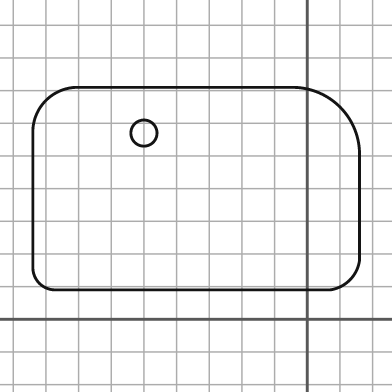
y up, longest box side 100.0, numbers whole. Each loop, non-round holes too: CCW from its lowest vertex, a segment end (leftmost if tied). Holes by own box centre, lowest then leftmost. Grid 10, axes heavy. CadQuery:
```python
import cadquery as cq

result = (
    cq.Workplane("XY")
    .moveTo(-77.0, 9.0)
    .lineTo(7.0, 9.0)
    .threePointArc((13.0, 12.0), (16.0, 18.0))
    .lineTo(16.0, 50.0)
    .threePointArc((10.0, 65.0), (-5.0, 71.0))
    .lineTo(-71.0, 71.0)
    .threePointArc((-80.0, 67.0), (-84.0, 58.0))
    .lineTo(-84.0, 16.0)
    .threePointArc((-82.0, 11.0), (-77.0, 9.0))
    .close()
    .moveTo(-50.0, 57.0)
    .circle(4.0)
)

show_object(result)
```